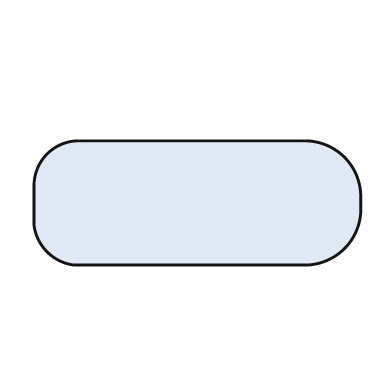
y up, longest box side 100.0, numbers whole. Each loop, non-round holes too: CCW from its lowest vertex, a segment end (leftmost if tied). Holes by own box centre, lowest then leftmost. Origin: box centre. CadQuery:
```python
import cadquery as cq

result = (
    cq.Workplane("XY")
    .moveTo(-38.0, -19.0)
    .lineTo(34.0, -19.0)
    .threePointArc((45.0, -14.0), (50.0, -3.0))
    .lineTo(50.0, 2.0)
    .threePointArc((45.0, 14.0), (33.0, 19.0))
    .lineTo(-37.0, 19.0)
    .threePointArc((-46.0, 15.0), (-50.0, 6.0))
    .lineTo(-50.0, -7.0)
    .threePointArc((-46.0, -15.0), (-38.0, -19.0))
    .close()
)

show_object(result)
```